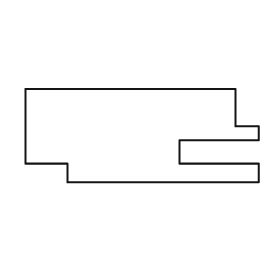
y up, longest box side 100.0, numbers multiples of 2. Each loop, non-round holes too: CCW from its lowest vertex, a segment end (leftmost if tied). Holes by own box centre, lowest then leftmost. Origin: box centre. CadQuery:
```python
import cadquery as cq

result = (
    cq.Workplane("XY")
    .moveTo(-32.0, -20.0)
    .lineTo(50.0, -20.0)
    .lineTo(50.0, -12.0)
    .lineTo(16.0, -12.0)
    .lineTo(16.0, -2.0)
    .lineTo(50.0, -2.0)
    .lineTo(50.0, 4.0)
    .lineTo(40.0, 4.0)
    .lineTo(40.0, 20.0)
    .lineTo(-50.0, 20.0)
    .lineTo(-50.0, -12.0)
    .lineTo(-32.0, -12.0)
    .close()
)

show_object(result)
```